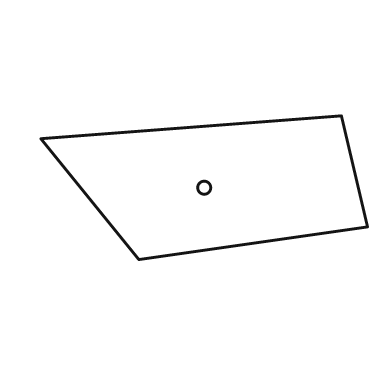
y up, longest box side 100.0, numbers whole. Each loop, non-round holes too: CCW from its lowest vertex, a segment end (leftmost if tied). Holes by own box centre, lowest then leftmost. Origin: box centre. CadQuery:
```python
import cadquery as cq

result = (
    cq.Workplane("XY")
    .moveTo(-20.0, -22.0)
    .lineTo(50.0, -12.0)
    .lineTo(42.0, 22.0)
    .lineTo(-50.0, 15.0)
    .close()
    .moveTo(0.0, 0.0)
    .circle(2.0)
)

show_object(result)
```